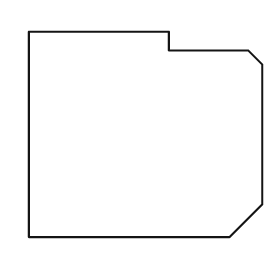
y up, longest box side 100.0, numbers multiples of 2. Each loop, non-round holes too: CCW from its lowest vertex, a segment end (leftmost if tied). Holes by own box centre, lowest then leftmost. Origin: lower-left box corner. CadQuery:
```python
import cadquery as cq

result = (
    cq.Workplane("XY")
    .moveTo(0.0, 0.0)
    .lineTo(86.0, 0.0)
    .lineTo(100.0, 14.0)
    .lineTo(100.0, 74.0)
    .lineTo(94.0, 80.0)
    .lineTo(60.0, 80.0)
    .lineTo(60.0, 88.0)
    .lineTo(0.0, 88.0)
    .close()
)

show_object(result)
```